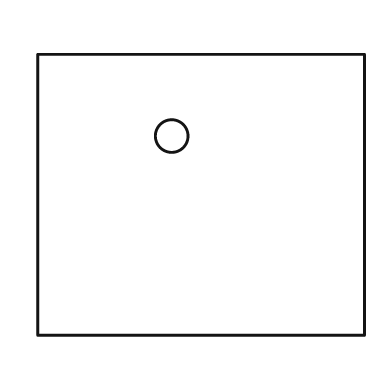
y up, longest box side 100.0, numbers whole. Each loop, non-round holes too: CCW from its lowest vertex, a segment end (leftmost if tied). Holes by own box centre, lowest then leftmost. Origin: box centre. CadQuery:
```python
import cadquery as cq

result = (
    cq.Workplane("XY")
    .moveTo(-50.0, -43.0)
    .lineTo(50.0, -43.0)
    .lineTo(50.0, 43.0)
    .lineTo(-50.0, 43.0)
    .close()
    .moveTo(-9.0, 18.0)
    .circle(5.0)
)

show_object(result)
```